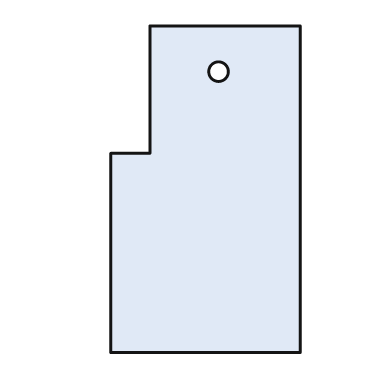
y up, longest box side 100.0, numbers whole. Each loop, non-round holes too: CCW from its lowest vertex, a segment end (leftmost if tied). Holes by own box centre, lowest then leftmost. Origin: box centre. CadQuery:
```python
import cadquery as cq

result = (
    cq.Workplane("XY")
    .moveTo(-29.0, -50.0)
    .lineTo(29.0, -50.0)
    .lineTo(29.0, 50.0)
    .lineTo(-17.0, 50.0)
    .lineTo(-17.0, 11.0)
    .lineTo(-29.0, 11.0)
    .close()
    .moveTo(4.0, 36.0)
    .circle(3.0)
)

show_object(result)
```